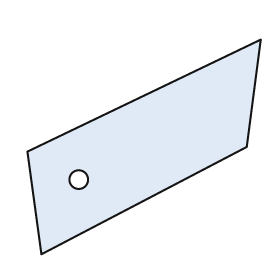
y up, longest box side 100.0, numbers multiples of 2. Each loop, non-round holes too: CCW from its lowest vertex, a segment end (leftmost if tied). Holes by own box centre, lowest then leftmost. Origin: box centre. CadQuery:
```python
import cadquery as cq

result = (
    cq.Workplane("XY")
    .moveTo(-44.0, -46.0)
    .lineTo(44.0, 0.0)
    .lineTo(50.0, 46.0)
    .lineTo(-50.0, -2.0)
    .close()
    .moveTo(-28.0, -14.0)
    .circle(4.0)
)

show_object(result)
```